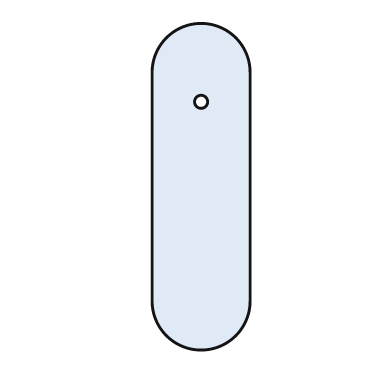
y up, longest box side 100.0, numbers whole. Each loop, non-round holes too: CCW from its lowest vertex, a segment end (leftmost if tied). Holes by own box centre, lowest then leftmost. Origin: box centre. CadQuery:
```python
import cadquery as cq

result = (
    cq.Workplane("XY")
    .moveTo(-15.0, -35.0)
    .threePointArc((0.0, -50.0), (15.0, -35.0))
    .lineTo(15.0, 35.0)
    .threePointArc((0.0, 50.0), (-15.0, 35.0))
    .close()
    .moveTo(0.0, 26.0)
    .circle(2.0)
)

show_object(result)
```